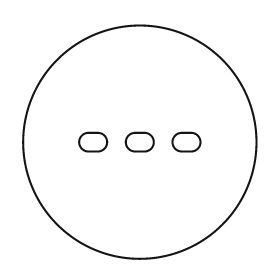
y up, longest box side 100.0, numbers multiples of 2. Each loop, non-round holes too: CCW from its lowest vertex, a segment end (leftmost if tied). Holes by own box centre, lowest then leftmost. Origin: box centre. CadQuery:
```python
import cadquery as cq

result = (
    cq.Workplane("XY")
    .moveTo(0.0, 0.0)
    .circle(50.0)
    .moveTo(-22.0, -4.0)
    .lineTo(-18.0, -4.0)
    .threePointArc((-14.0, 0.0), (-18.0, 4.0))
    .lineTo(-22.0, 4.0)
    .threePointArc((-26.0, 0.0), (-22.0, -4.0))
    .close()
    .moveTo(-2.0, -4.0)
    .lineTo(2.0, -4.0)
    .threePointArc((6.0, 0.0), (2.0, 4.0))
    .lineTo(-2.0, 4.0)
    .threePointArc((-6.0, 0.0), (-2.0, -4.0))
    .close()
    .moveTo(18.0, -4.0)
    .lineTo(22.0, -4.0)
    .threePointArc((26.0, 0.0), (22.0, 4.0))
    .lineTo(18.0, 4.0)
    .threePointArc((14.0, 0.0), (18.0, -4.0))
    .close()
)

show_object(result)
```